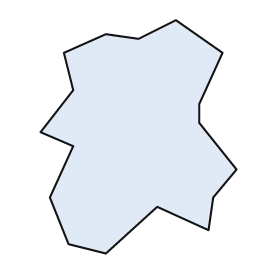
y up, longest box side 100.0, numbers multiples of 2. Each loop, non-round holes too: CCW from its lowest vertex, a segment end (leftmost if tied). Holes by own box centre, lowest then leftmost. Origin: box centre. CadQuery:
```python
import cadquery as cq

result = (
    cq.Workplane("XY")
    .moveTo(-14.0, -50.0)
    .lineTo(8.0, -30.0)
    .lineTo(30.0, -40.0)
    .lineTo(32.0, -26.0)
    .lineTo(42.0, -14.0)
    .lineTo(26.0, 6.0)
    .lineTo(26.0, 14.0)
    .lineTo(36.0, 36.0)
    .lineTo(16.0, 50.0)
    .lineTo(0.0, 42.0)
    .lineTo(-14.0, 44.0)
    .lineTo(-32.0, 36.0)
    .lineTo(-28.0, 20.0)
    .lineTo(-42.0, 2.0)
    .lineTo(-28.0, -4.0)
    .lineTo(-38.0, -26.0)
    .lineTo(-30.0, -46.0)
    .close()
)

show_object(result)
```